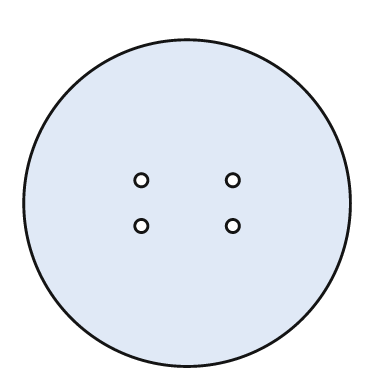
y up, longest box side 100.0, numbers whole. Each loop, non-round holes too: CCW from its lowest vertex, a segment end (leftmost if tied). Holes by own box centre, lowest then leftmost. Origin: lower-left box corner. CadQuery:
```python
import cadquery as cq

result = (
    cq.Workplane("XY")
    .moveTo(50.0, 50.0)
    .circle(50.0)
    .moveTo(36.0, 43.0)
    .circle(2.0)
    .moveTo(64.0, 43.0)
    .circle(2.0)
    .moveTo(36.0, 57.0)
    .circle(2.0)
    .moveTo(64.0, 57.0)
    .circle(2.0)
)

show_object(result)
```